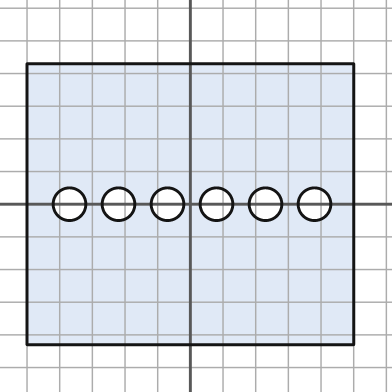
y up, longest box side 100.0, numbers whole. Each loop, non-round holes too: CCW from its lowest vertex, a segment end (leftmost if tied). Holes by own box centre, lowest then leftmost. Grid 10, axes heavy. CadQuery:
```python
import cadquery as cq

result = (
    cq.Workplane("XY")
    .moveTo(-50.0, -43.0)
    .lineTo(50.0, -43.0)
    .lineTo(50.0, 43.0)
    .lineTo(-50.0, 43.0)
    .close()
    .moveTo(-37.0, 0.0)
    .circle(5.0)
    .moveTo(-22.0, 0.0)
    .circle(5.0)
    .moveTo(-7.0, 0.0)
    .circle(5.0)
    .moveTo(8.0, 0.0)
    .circle(5.0)
    .moveTo(23.0, 0.0)
    .circle(5.0)
    .moveTo(38.0, 0.0)
    .circle(5.0)
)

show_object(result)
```